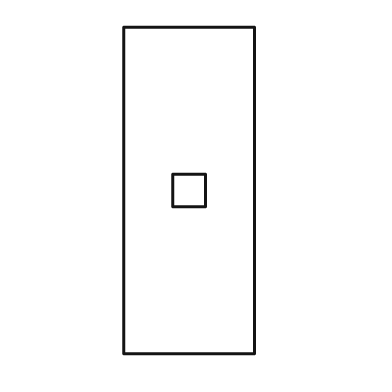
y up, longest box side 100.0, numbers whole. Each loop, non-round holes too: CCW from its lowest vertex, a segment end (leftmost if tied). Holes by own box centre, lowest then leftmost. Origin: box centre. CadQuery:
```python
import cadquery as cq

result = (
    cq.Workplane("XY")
    .moveTo(-20.0, -50.0)
    .lineTo(20.0, -50.0)
    .lineTo(20.0, 50.0)
    .lineTo(-20.0, 50.0)
    .close()
    .moveTo(-5.0, -5.0)
    .lineTo(5.0, -5.0)
    .lineTo(5.0, 5.0)
    .lineTo(-5.0, 5.0)
    .close()
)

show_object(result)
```